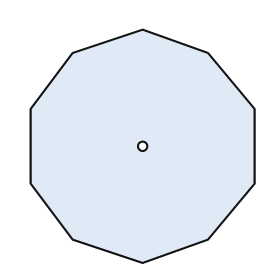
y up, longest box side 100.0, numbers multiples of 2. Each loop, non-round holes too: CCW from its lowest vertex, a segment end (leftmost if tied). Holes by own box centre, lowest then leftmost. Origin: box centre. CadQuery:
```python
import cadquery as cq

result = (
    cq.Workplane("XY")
    .moveTo(0.0, -50.0)
    .lineTo(28.0, -40.0)
    .lineTo(48.0, -16.0)
    .lineTo(48.0, 16.0)
    .lineTo(28.0, 40.0)
    .lineTo(0.0, 50.0)
    .lineTo(-30.0, 40.0)
    .lineTo(-48.0, 16.0)
    .lineTo(-48.0, -16.0)
    .lineTo(-30.0, -40.0)
    .close()
    .moveTo(0.0, 0.0)
    .circle(2.0)
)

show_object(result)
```